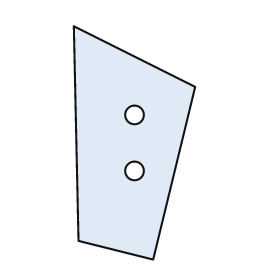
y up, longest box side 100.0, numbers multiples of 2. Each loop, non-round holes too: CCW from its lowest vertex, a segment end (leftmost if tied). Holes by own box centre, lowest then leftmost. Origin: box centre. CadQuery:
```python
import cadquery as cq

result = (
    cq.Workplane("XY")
    .moveTo(8.0, -50.0)
    .lineTo(26.0, 24.0)
    .lineTo(-26.0, 50.0)
    .lineTo(-24.0, -42.0)
    .close()
    .moveTo(0.0, -12.0)
    .circle(4.0)
    .moveTo(0.0, 12.0)
    .circle(4.0)
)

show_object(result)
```